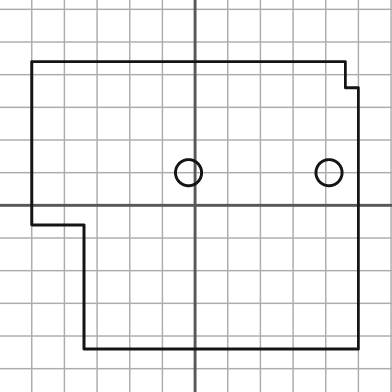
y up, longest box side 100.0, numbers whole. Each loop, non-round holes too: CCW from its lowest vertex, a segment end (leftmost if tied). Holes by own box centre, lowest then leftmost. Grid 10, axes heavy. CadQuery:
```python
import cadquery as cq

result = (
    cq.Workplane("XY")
    .moveTo(-34.0, -44.0)
    .lineTo(50.0, -44.0)
    .lineTo(50.0, 36.0)
    .lineTo(46.0, 36.0)
    .lineTo(46.0, 44.0)
    .lineTo(-50.0, 44.0)
    .lineTo(-50.0, -6.0)
    .lineTo(-34.0, -6.0)
    .close()
    .moveTo(-2.0, 10.0)
    .circle(4.0)
    .moveTo(41.0, 10.0)
    .circle(4.0)
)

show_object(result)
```